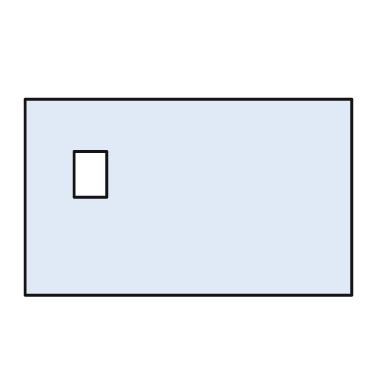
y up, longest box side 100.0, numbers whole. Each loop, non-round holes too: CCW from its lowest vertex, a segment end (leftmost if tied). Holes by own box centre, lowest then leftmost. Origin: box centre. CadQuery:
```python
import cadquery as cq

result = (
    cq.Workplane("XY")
    .moveTo(-50.0, -30.0)
    .lineTo(50.0, -30.0)
    .lineTo(50.0, 30.0)
    .lineTo(-50.0, 30.0)
    .close()
    .moveTo(-35.0, 0.0)
    .lineTo(-25.0, 0.0)
    .lineTo(-25.0, 14.0)
    .lineTo(-35.0, 14.0)
    .close()
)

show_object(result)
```